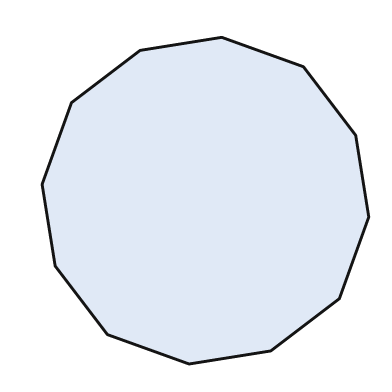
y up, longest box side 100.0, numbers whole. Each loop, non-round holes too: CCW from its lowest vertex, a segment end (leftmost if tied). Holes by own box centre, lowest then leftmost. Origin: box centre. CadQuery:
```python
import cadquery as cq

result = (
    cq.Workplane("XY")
    .moveTo(-5.0, -50.0)
    .lineTo(20.0, -46.0)
    .lineTo(41.0, -30.0)
    .lineTo(50.0, -5.0)
    .lineTo(46.0, 20.0)
    .lineTo(30.0, 41.0)
    .lineTo(5.0, 50.0)
    .lineTo(-20.0, 46.0)
    .lineTo(-41.0, 30.0)
    .lineTo(-50.0, 5.0)
    .lineTo(-46.0, -20.0)
    .lineTo(-30.0, -41.0)
    .close()
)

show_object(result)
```